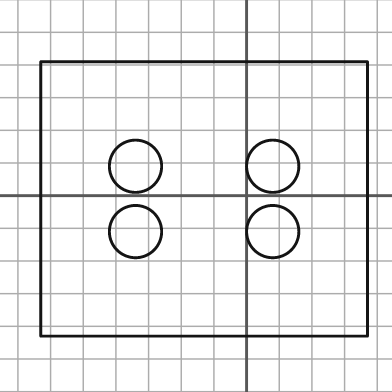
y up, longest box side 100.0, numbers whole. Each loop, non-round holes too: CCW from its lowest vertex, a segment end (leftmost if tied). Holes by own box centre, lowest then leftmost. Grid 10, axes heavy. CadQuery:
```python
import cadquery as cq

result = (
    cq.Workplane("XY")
    .moveTo(-63.0, -43.0)
    .lineTo(37.0, -43.0)
    .lineTo(37.0, 41.0)
    .lineTo(-63.0, 41.0)
    .close()
    .moveTo(-34.0, -11.0)
    .circle(8.0)
    .moveTo(8.0, -11.0)
    .circle(8.0)
    .moveTo(-34.0, 9.0)
    .circle(8.0)
    .moveTo(8.0, 9.0)
    .circle(8.0)
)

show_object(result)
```